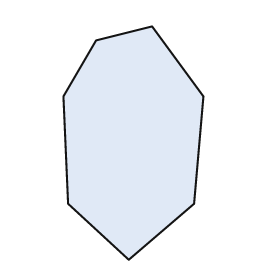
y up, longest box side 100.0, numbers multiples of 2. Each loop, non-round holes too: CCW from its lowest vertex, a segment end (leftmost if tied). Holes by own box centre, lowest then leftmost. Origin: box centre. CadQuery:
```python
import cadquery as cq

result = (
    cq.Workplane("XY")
    .moveTo(-2.0, -50.0)
    .lineTo(26.0, -26.0)
    .lineTo(30.0, 20.0)
    .lineTo(8.0, 50.0)
    .lineTo(-16.0, 44.0)
    .lineTo(-30.0, 20.0)
    .lineTo(-28.0, -26.0)
    .close()
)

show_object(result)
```